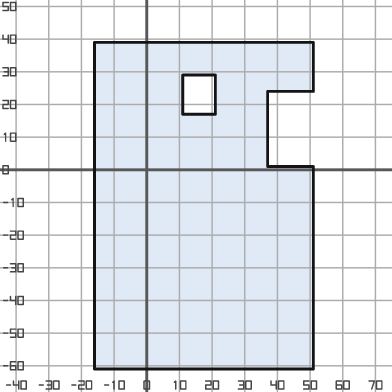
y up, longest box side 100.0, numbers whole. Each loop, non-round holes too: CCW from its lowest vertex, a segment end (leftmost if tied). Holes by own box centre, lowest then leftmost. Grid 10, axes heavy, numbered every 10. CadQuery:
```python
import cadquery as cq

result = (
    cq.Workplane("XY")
    .moveTo(-16.0, -61.0)
    .lineTo(51.0, -61.0)
    .lineTo(51.0, 1.0)
    .lineTo(37.0, 1.0)
    .lineTo(37.0, 24.0)
    .lineTo(51.0, 24.0)
    .lineTo(51.0, 39.0)
    .lineTo(-16.0, 39.0)
    .close()
    .moveTo(11.0, 17.0)
    .lineTo(21.0, 17.0)
    .lineTo(21.0, 29.0)
    .lineTo(11.0, 29.0)
    .close()
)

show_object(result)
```